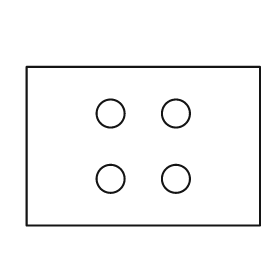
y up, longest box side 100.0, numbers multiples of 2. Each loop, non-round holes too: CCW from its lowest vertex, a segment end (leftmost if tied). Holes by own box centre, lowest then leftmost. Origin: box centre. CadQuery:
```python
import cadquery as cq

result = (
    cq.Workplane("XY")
    .moveTo(-50.0, -34.0)
    .lineTo(50.0, -34.0)
    .lineTo(50.0, 34.0)
    .lineTo(-50.0, 34.0)
    .close()
    .moveTo(-14.0, -14.0)
    .circle(6.0)
    .moveTo(14.0, -14.0)
    .circle(6.0)
    .moveTo(-14.0, 14.0)
    .circle(6.0)
    .moveTo(14.0, 14.0)
    .circle(6.0)
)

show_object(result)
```